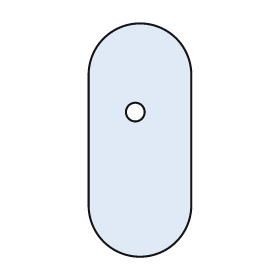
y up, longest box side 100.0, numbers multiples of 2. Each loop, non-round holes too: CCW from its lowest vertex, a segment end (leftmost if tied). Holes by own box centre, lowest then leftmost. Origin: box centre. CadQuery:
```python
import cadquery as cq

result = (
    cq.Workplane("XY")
    .moveTo(-22.0, -28.0)
    .threePointArc((0.0, -50.0), (22.0, -28.0))
    .lineTo(22.0, 28.0)
    .threePointArc((0.0, 50.0), (-22.0, 28.0))
    .close()
    .moveTo(-2.0, 12.0)
    .circle(4.0)
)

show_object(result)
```